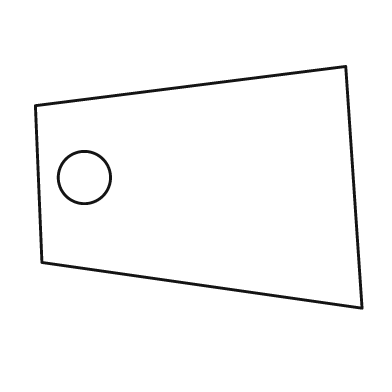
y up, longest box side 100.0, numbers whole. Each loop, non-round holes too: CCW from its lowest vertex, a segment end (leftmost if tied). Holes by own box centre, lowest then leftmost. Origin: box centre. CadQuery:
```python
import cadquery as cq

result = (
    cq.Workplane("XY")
    .moveTo(50.0, -37.0)
    .lineTo(45.0, 37.0)
    .lineTo(-50.0, 25.0)
    .lineTo(-48.0, -23.0)
    .close()
    .moveTo(-35.0, 3.0)
    .circle(8.0)
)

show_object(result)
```